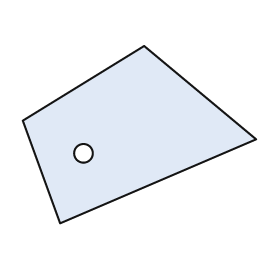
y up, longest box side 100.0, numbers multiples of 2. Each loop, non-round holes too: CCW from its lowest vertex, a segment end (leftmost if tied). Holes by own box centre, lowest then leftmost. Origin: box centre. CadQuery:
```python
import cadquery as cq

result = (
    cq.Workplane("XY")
    .moveTo(-34.0, -38.0)
    .lineTo(50.0, -2.0)
    .lineTo(2.0, 38.0)
    .lineTo(-50.0, 6.0)
    .close()
    .moveTo(-24.0, -8.0)
    .circle(4.0)
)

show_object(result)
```